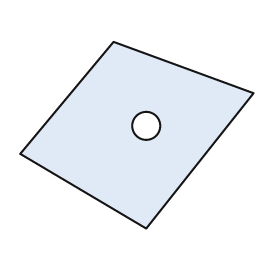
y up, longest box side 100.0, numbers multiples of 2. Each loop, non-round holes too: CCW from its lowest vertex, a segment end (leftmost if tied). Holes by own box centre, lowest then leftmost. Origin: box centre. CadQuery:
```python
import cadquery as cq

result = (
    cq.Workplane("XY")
    .moveTo(4.0, -40.0)
    .lineTo(50.0, 18.0)
    .lineTo(-10.0, 40.0)
    .lineTo(-50.0, -8.0)
    .close()
    .moveTo(4.0, 4.0)
    .circle(6.0)
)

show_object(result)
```